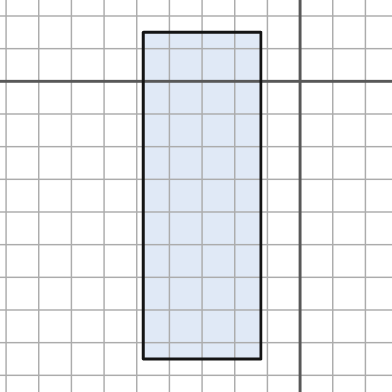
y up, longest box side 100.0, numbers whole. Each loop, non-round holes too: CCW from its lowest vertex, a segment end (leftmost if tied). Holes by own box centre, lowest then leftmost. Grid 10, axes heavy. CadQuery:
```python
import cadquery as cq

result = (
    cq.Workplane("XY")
    .moveTo(-48.0, -85.0)
    .lineTo(-12.0, -85.0)
    .lineTo(-12.0, 15.0)
    .lineTo(-48.0, 15.0)
    .close()
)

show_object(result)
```